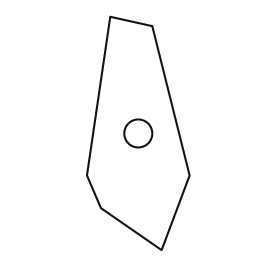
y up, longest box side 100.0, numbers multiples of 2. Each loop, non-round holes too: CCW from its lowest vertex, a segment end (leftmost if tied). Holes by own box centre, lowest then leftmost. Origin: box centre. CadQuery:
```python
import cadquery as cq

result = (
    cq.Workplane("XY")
    .moveTo(10.0, -50.0)
    .lineTo(22.0, -18.0)
    .lineTo(6.0, 46.0)
    .lineTo(-12.0, 50.0)
    .lineTo(-22.0, -18.0)
    .lineTo(-16.0, -32.0)
    .close()
    .moveTo(0.0, 0.0)
    .circle(6.0)
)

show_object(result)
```